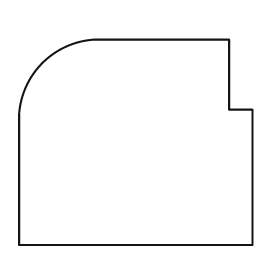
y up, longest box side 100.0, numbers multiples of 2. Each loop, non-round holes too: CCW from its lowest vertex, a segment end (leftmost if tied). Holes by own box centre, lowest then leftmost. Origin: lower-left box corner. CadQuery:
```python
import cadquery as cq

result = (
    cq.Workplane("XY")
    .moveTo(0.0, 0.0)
    .lineTo(100.0, 0.0)
    .lineTo(100.0, 58.0)
    .lineTo(90.0, 58.0)
    .lineTo(90.0, 88.0)
    .lineTo(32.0, 88.0)
    .threePointArc((10.0, 78.0), (0.0, 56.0))
    .close()
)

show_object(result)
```